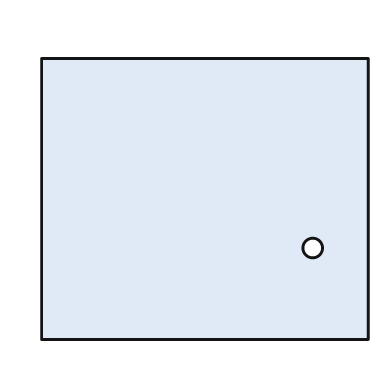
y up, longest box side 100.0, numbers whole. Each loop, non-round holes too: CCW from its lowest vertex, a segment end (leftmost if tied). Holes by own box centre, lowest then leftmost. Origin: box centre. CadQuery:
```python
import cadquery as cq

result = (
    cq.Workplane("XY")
    .moveTo(-50.0, -43.0)
    .lineTo(50.0, -43.0)
    .lineTo(50.0, 43.0)
    .lineTo(-50.0, 43.0)
    .close()
    .moveTo(33.0, -15.0)
    .circle(3.0)
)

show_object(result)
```